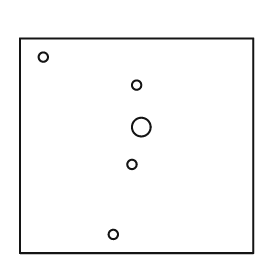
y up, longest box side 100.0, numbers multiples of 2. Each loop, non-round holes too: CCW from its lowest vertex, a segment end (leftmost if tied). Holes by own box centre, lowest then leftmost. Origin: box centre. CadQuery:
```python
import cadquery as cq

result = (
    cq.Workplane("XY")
    .moveTo(-50.0, -46.0)
    .lineTo(50.0, -46.0)
    .lineTo(50.0, 46.0)
    .lineTo(-50.0, 46.0)
    .close()
    .moveTo(-10.0, -38.0)
    .circle(2.0)
    .moveTo(-2.0, -8.0)
    .circle(2.0)
    .moveTo(2.0, 8.0)
    .circle(4.0)
    .moveTo(0.0, 26.0)
    .circle(2.0)
    .moveTo(-40.0, 38.0)
    .circle(2.0)
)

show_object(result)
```